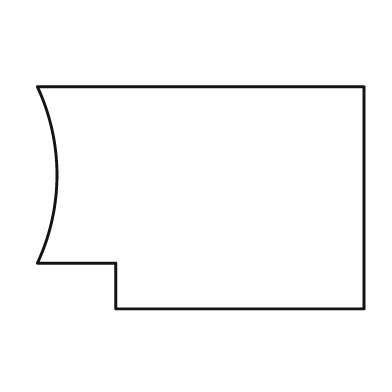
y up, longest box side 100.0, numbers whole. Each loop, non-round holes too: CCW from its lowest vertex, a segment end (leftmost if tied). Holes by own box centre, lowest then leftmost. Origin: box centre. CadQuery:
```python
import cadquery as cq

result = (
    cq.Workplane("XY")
    .moveTo(-26.0, -34.0)
    .lineTo(50.0, -34.0)
    .lineTo(50.0, 34.0)
    .lineTo(-50.0, 34.0)
    .threePointArc((-44.0, 7.0), (-50.0, -20.0))
    .lineTo(-26.0, -20.0)
    .close()
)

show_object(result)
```